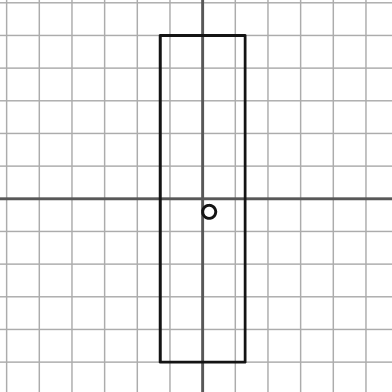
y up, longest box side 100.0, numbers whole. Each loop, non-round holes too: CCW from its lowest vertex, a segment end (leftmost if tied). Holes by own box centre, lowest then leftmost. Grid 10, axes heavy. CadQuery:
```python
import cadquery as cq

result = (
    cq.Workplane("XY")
    .moveTo(-13.0, -50.0)
    .lineTo(13.0, -50.0)
    .lineTo(13.0, 50.0)
    .lineTo(-13.0, 50.0)
    .close()
    .moveTo(2.0, -4.0)
    .circle(2.0)
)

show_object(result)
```